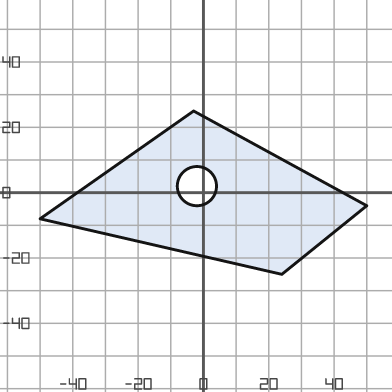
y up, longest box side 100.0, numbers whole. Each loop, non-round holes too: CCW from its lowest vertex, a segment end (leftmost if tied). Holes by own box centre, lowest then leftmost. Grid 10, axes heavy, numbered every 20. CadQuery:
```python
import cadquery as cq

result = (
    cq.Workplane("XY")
    .moveTo(24.0, -25.0)
    .lineTo(50.0, -4.0)
    .lineTo(-3.0, 25.0)
    .lineTo(-50.0, -8.0)
    .close()
    .moveTo(-2.0, 2.0)
    .circle(6.0)
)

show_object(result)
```